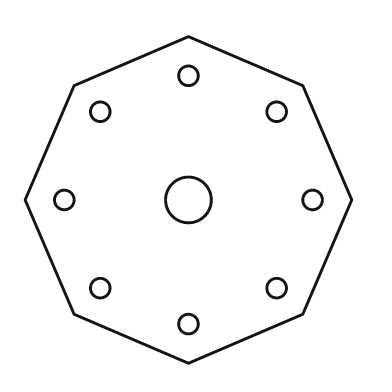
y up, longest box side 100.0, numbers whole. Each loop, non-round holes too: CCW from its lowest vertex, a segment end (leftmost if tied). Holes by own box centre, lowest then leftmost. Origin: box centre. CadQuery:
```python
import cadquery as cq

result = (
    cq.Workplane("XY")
    .moveTo(0.0, -50.0)
    .lineTo(35.0, -35.0)
    .lineTo(50.0, 0.0)
    .lineTo(35.0, 35.0)
    .lineTo(0.0, 50.0)
    .lineTo(-35.0, 35.0)
    .lineTo(-50.0, 0.0)
    .lineTo(-35.0, -35.0)
    .close()
    .moveTo(0.0, -38.0)
    .circle(3.0)
    .moveTo(-27.0, -27.0)
    .circle(3.0)
    .moveTo(27.0, -27.0)
    .circle(3.0)
    .moveTo(-38.0, 0.0)
    .circle(3.0)
    .moveTo(0.0, 0.0)
    .circle(7.0)
    .moveTo(38.0, 0.0)
    .circle(3.0)
    .moveTo(-27.0, 27.0)
    .circle(3.0)
    .moveTo(27.0, 27.0)
    .circle(3.0)
    .moveTo(0.0, 38.0)
    .circle(3.0)
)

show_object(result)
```